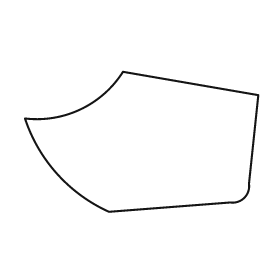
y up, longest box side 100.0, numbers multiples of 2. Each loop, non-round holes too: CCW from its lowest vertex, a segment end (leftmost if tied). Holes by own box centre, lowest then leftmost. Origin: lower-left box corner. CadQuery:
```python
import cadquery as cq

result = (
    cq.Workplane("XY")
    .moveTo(36.0, 0.0)
    .lineTo(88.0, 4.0)
    .threePointArc((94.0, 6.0), (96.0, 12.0))
    .lineTo(100.0, 50.0)
    .lineTo(42.0, 60.0)
    .threePointArc((24.0, 44.0), (0.0, 40.0))
    .threePointArc((14.0, 16.0), (36.0, 0.0))
    .close()
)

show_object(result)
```